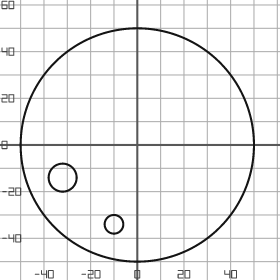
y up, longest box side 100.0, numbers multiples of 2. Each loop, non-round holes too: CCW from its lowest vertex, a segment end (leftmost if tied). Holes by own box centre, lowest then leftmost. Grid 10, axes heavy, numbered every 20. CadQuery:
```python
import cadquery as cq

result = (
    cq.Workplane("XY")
    .moveTo(0.0, 0.0)
    .circle(50.0)
    .moveTo(-10.0, -34.0)
    .circle(4.0)
    .moveTo(-32.0, -14.0)
    .circle(6.0)
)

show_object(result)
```